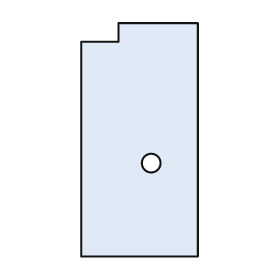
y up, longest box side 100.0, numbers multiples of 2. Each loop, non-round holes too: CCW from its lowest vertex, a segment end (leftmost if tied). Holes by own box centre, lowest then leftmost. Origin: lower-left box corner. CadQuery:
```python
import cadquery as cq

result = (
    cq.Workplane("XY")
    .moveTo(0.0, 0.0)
    .lineTo(50.0, 0.0)
    .lineTo(50.0, 100.0)
    .lineTo(16.0, 100.0)
    .lineTo(16.0, 92.0)
    .lineTo(0.0, 92.0)
    .close()
    .moveTo(30.0, 40.0)
    .circle(4.0)
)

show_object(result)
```